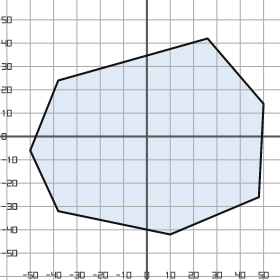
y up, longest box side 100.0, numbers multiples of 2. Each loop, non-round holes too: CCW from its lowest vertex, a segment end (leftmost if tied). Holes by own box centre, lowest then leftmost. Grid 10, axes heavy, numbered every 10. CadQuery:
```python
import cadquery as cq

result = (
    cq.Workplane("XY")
    .moveTo(10.0, -42.0)
    .lineTo(48.0, -26.0)
    .lineTo(50.0, 14.0)
    .lineTo(26.0, 42.0)
    .lineTo(-38.0, 24.0)
    .lineTo(-50.0, -6.0)
    .lineTo(-38.0, -32.0)
    .close()
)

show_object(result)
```